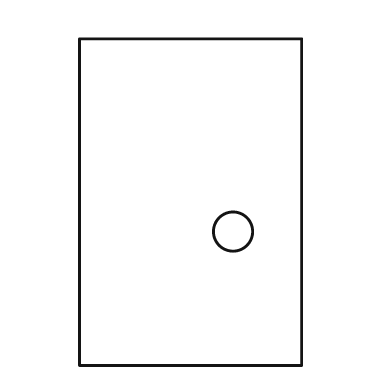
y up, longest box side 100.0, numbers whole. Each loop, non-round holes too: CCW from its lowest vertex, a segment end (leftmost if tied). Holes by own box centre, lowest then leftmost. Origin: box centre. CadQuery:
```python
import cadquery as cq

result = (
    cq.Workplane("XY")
    .moveTo(-34.0, -50.0)
    .lineTo(34.0, -50.0)
    .lineTo(34.0, 50.0)
    .lineTo(-34.0, 50.0)
    .close()
    .moveTo(13.0, -9.0)
    .circle(6.0)
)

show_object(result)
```